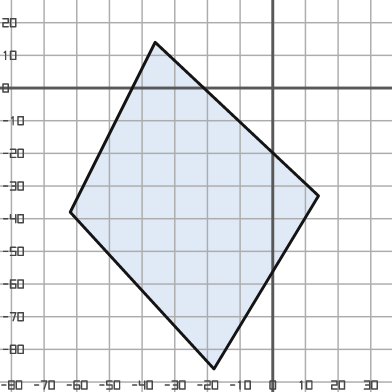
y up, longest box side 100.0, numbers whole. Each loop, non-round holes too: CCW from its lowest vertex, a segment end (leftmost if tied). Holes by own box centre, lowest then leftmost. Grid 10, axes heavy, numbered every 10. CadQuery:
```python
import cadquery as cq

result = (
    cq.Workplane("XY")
    .moveTo(-18.0, -86.0)
    .lineTo(14.0, -33.0)
    .lineTo(-36.0, 14.0)
    .lineTo(-62.0, -38.0)
    .close()
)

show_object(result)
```